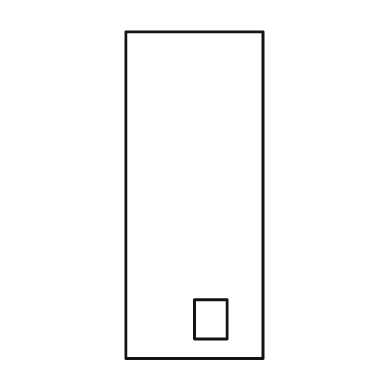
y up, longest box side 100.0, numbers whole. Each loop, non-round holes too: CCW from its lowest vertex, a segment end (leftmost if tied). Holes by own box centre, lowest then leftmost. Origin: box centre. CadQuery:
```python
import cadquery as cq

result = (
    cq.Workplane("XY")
    .moveTo(-21.0, -50.0)
    .lineTo(21.0, -50.0)
    .lineTo(21.0, 50.0)
    .lineTo(-21.0, 50.0)
    .close()
    .moveTo(0.0, -44.0)
    .lineTo(10.0, -44.0)
    .lineTo(10.0, -32.0)
    .lineTo(0.0, -32.0)
    .close()
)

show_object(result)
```